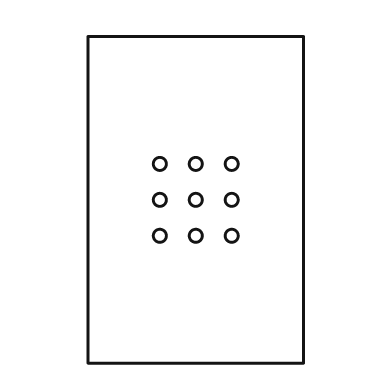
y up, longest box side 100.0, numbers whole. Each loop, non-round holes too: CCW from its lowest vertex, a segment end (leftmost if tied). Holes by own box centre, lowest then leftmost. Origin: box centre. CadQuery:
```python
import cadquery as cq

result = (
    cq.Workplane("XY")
    .moveTo(-33.0, -50.0)
    .lineTo(33.0, -50.0)
    .lineTo(33.0, 50.0)
    .lineTo(-33.0, 50.0)
    .close()
    .moveTo(-11.0, -11.0)
    .circle(2.0)
    .moveTo(0.0, -11.0)
    .circle(2.0)
    .moveTo(11.0, -11.0)
    .circle(2.0)
    .moveTo(-11.0, 0.0)
    .circle(2.0)
    .moveTo(0.0, 0.0)
    .circle(2.0)
    .moveTo(11.0, 0.0)
    .circle(2.0)
    .moveTo(-11.0, 11.0)
    .circle(2.0)
    .moveTo(0.0, 11.0)
    .circle(2.0)
    .moveTo(11.0, 11.0)
    .circle(2.0)
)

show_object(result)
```